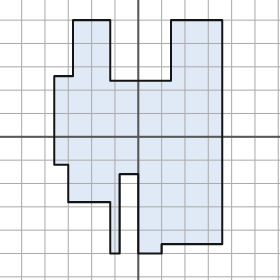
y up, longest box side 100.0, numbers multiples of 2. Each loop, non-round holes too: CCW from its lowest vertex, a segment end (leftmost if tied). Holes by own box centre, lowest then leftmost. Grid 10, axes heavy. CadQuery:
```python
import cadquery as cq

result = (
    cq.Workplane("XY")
    .moveTo(-12.0, -50.0)
    .lineTo(-8.0, -50.0)
    .lineTo(-8.0, -16.0)
    .lineTo(0.0, -16.0)
    .lineTo(0.0, -50.0)
    .lineTo(10.0, -50.0)
    .lineTo(10.0, -46.0)
    .lineTo(36.0, -46.0)
    .lineTo(36.0, 50.0)
    .lineTo(14.0, 50.0)
    .lineTo(14.0, 24.0)
    .lineTo(-12.0, 24.0)
    .lineTo(-12.0, 50.0)
    .lineTo(-28.0, 50.0)
    .lineTo(-28.0, 26.0)
    .lineTo(-36.0, 26.0)
    .lineTo(-36.0, -12.0)
    .lineTo(-30.0, -12.0)
    .lineTo(-30.0, -28.0)
    .lineTo(-12.0, -28.0)
    .close()
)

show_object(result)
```